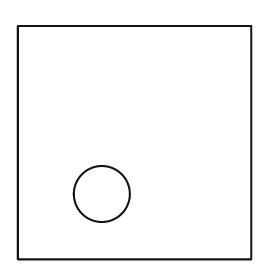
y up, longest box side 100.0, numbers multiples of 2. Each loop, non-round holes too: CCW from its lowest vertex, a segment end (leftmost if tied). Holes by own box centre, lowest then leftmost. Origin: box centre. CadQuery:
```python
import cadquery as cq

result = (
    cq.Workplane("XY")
    .moveTo(-50.0, -50.0)
    .lineTo(50.0, -50.0)
    .lineTo(50.0, 50.0)
    .lineTo(-50.0, 50.0)
    .close()
    .moveTo(-14.0, -22.0)
    .circle(12.0)
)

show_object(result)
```